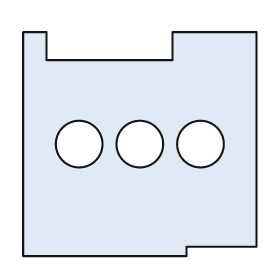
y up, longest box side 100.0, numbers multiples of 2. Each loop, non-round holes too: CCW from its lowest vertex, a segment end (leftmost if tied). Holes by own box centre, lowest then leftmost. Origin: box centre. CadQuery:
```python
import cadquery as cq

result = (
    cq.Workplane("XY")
    .moveTo(-50.0, -48.0)
    .lineTo(20.0, -48.0)
    .lineTo(20.0, -44.0)
    .lineTo(50.0, -44.0)
    .lineTo(50.0, 48.0)
    .lineTo(14.0, 48.0)
    .lineTo(14.0, 36.0)
    .lineTo(-40.0, 36.0)
    .lineTo(-40.0, 48.0)
    .lineTo(-50.0, 48.0)
    .close()
    .moveTo(-26.0, 0.0)
    .circle(10.0)
    .moveTo(0.0, 0.0)
    .circle(10.0)
    .moveTo(26.0, 0.0)
    .circle(10.0)
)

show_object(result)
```